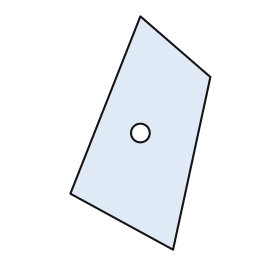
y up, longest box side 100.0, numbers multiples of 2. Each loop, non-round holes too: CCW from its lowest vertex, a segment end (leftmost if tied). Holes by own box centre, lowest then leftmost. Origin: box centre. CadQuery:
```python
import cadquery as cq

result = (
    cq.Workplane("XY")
    .moveTo(14.0, -50.0)
    .lineTo(30.0, 24.0)
    .lineTo(0.0, 50.0)
    .lineTo(-30.0, -26.0)
    .close()
    .moveTo(0.0, 0.0)
    .circle(4.0)
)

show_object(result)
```